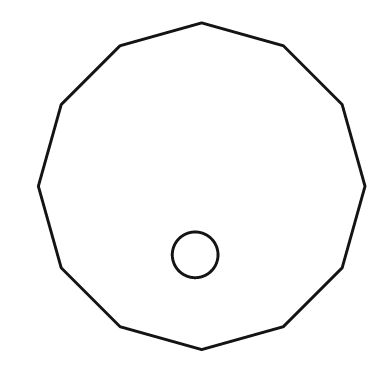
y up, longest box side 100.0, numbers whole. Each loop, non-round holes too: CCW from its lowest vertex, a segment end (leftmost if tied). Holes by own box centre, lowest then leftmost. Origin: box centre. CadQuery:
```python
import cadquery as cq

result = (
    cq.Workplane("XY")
    .moveTo(0.0, -50.0)
    .lineTo(25.0, -43.0)
    .lineTo(43.0, -25.0)
    .lineTo(50.0, 0.0)
    .lineTo(43.0, 25.0)
    .lineTo(25.0, 43.0)
    .lineTo(0.0, 50.0)
    .lineTo(-25.0, 43.0)
    .lineTo(-43.0, 25.0)
    .lineTo(-50.0, 0.0)
    .lineTo(-43.0, -25.0)
    .lineTo(-25.0, -43.0)
    .close()
    .moveTo(-2.0, -21.0)
    .circle(7.0)
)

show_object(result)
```